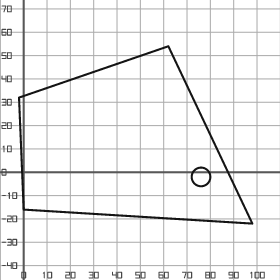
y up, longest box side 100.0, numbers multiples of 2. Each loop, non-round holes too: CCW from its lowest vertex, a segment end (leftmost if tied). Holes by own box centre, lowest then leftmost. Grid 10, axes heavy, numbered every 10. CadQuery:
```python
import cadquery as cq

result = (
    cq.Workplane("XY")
    .moveTo(98.0, -22.0)
    .lineTo(62.0, 54.0)
    .lineTo(-2.0, 32.0)
    .lineTo(0.0, -16.0)
    .close()
    .moveTo(76.0, -2.0)
    .circle(4.0)
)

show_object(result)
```